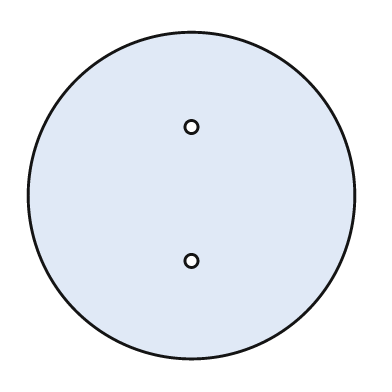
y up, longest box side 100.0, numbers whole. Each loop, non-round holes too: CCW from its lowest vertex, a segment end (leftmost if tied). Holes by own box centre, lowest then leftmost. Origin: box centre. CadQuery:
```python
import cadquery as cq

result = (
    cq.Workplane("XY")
    .moveTo(0.0, 0.0)
    .circle(50.0)
    .moveTo(0.0, -20.0)
    .circle(2.0)
    .moveTo(0.0, 21.0)
    .circle(2.0)
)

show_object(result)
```